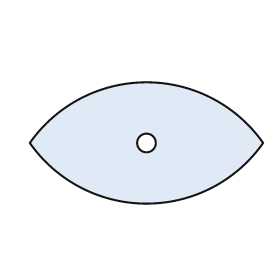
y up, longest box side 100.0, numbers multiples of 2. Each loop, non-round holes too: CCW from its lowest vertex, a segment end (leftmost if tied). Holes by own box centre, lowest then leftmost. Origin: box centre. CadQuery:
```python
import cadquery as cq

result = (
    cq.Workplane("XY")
    .moveTo(-50.0, 0.0)
    .threePointArc((0.0, -26.0), (50.0, 0.0))
    .threePointArc((0.0, 26.0), (-50.0, 0.0))
    .close()
    .moveTo(0.0, 0.0)
    .circle(4.0)
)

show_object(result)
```